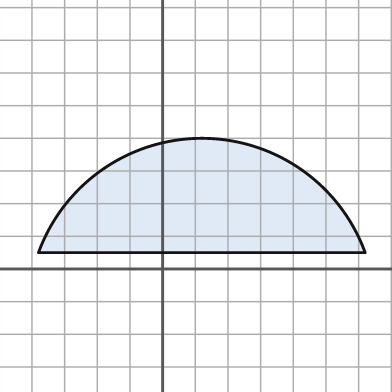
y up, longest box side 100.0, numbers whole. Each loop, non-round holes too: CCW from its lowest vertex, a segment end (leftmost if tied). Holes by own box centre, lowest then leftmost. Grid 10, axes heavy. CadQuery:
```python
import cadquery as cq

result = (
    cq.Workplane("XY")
    .moveTo(-38.0, 5.0)
    .lineTo(62.0, 5.0)
    .threePointArc((12.0, 40.0), (-38.0, 5.0))
    .close()
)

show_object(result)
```